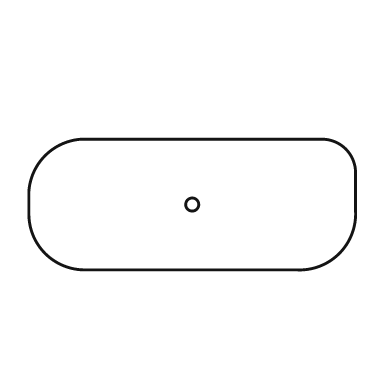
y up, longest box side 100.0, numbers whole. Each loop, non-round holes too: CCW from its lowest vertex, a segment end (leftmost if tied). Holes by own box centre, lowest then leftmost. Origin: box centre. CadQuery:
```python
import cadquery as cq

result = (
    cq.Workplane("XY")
    .moveTo(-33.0, -20.0)
    .lineTo(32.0, -20.0)
    .threePointArc((45.0, -15.0), (50.0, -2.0))
    .lineTo(50.0, 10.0)
    .threePointArc((47.0, 17.0), (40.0, 20.0))
    .lineTo(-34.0, 20.0)
    .threePointArc((-45.0, 15.0), (-50.0, 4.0))
    .lineTo(-50.0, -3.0)
    .threePointArc((-45.0, -15.0), (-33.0, -20.0))
    .close()
    .moveTo(0.0, 0.0)
    .circle(2.0)
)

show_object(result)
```